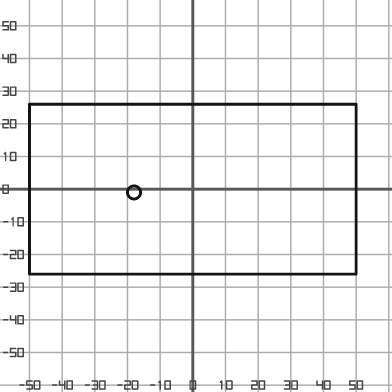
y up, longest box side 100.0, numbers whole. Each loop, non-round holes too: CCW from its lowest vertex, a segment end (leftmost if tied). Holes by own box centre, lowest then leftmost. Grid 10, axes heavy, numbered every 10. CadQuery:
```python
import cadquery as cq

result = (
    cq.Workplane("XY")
    .moveTo(-50.0, -26.0)
    .lineTo(50.0, -26.0)
    .lineTo(50.0, 26.0)
    .lineTo(-50.0, 26.0)
    .close()
    .moveTo(-18.0, -1.0)
    .circle(2.0)
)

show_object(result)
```